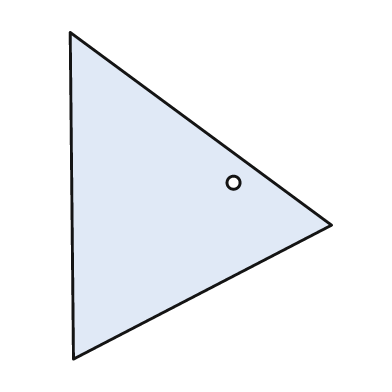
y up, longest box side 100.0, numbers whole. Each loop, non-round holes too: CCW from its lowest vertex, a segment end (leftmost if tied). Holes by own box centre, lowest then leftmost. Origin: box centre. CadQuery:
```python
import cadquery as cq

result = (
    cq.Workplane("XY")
    .moveTo(-39.0, -50.0)
    .lineTo(40.0, -9.0)
    .lineTo(-40.0, 50.0)
    .close()
    .moveTo(10.0, 4.0)
    .circle(2.0)
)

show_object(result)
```